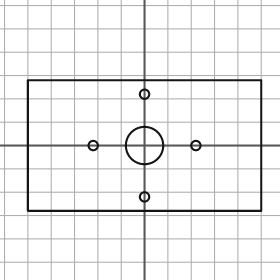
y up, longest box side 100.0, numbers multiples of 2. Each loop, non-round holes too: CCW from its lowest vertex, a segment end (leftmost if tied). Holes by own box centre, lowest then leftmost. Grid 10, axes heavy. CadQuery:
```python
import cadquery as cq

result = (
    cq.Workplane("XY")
    .moveTo(-50.0, -28.0)
    .lineTo(50.0, -28.0)
    .lineTo(50.0, 28.0)
    .lineTo(-50.0, 28.0)
    .close()
    .moveTo(0.0, -22.0)
    .circle(2.0)
    .moveTo(-22.0, 0.0)
    .circle(2.0)
    .moveTo(0.0, 0.0)
    .circle(8.0)
    .moveTo(22.0, 0.0)
    .circle(2.0)
    .moveTo(0.0, 22.0)
    .circle(2.0)
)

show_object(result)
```